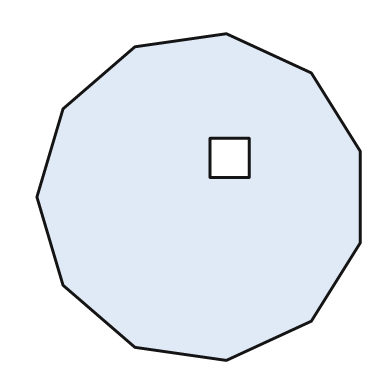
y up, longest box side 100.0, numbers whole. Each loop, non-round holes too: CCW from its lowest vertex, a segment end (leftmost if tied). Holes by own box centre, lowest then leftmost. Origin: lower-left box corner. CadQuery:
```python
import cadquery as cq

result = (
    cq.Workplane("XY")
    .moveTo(58.0, 0.0)
    .lineTo(84.0, 12.0)
    .lineTo(99.0, 36.0)
    .lineTo(99.0, 64.0)
    .lineTo(84.0, 88.0)
    .lineTo(58.0, 100.0)
    .lineTo(30.0, 96.0)
    .lineTo(8.0, 77.0)
    .lineTo(0.0, 50.0)
    .lineTo(8.0, 23.0)
    .lineTo(30.0, 4.0)
    .close()
    .moveTo(53.0, 56.0)
    .lineTo(65.0, 56.0)
    .lineTo(65.0, 68.0)
    .lineTo(53.0, 68.0)
    .close()
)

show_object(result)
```